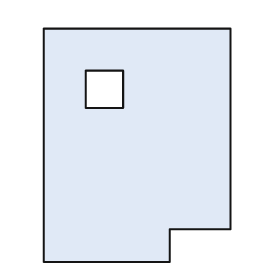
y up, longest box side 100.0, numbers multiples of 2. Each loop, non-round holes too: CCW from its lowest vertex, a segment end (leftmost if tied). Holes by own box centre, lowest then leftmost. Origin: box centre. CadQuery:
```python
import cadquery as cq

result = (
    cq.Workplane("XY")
    .moveTo(-40.0, -50.0)
    .lineTo(14.0, -50.0)
    .lineTo(14.0, -36.0)
    .lineTo(40.0, -36.0)
    .lineTo(40.0, 50.0)
    .lineTo(-40.0, 50.0)
    .close()
    .moveTo(-22.0, 16.0)
    .lineTo(-6.0, 16.0)
    .lineTo(-6.0, 32.0)
    .lineTo(-22.0, 32.0)
    .close()
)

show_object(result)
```